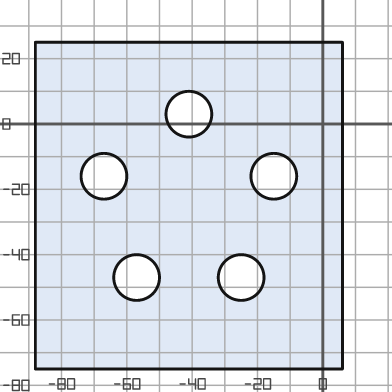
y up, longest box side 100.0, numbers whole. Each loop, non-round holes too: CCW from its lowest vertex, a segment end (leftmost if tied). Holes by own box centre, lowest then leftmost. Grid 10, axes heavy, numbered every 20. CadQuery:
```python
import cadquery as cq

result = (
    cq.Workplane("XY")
    .moveTo(-88.0, -75.0)
    .lineTo(6.0, -75.0)
    .lineTo(6.0, 25.0)
    .lineTo(-88.0, 25.0)
    .close()
    .moveTo(-57.0, -47.0)
    .circle(7.0)
    .moveTo(-25.0, -47.0)
    .circle(7.0)
    .moveTo(-67.0, -16.0)
    .circle(7.0)
    .moveTo(-15.0, -16.0)
    .circle(7.0)
    .moveTo(-41.0, 3.0)
    .circle(7.0)
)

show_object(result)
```